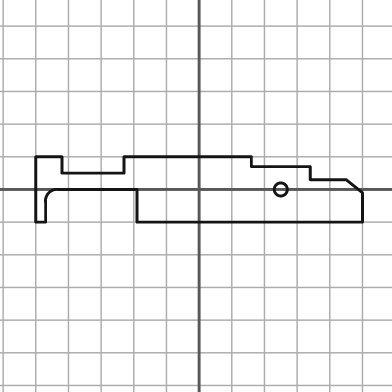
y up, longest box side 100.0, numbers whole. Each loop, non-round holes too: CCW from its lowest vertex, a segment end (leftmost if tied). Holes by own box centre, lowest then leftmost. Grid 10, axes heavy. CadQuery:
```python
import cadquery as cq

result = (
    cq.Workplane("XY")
    .moveTo(-50.0, -10.0)
    .lineTo(-47.0, -10.0)
    .lineTo(-47.0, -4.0)
    .threePointArc((-46.0, -1.0), (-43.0, 0.0))
    .lineTo(-19.0, 0.0)
    .lineTo(-19.0, -10.0)
    .lineTo(50.0, -10.0)
    .lineTo(50.0, -1.0)
    .lineTo(45.0, 3.0)
    .lineTo(34.0, 3.0)
    .lineTo(34.0, 7.0)
    .lineTo(16.0, 7.0)
    .lineTo(16.0, 10.0)
    .lineTo(-23.0, 10.0)
    .lineTo(-23.0, 5.0)
    .lineTo(-42.0, 5.0)
    .lineTo(-42.0, 10.0)
    .lineTo(-50.0, 10.0)
    .close()
    .moveTo(25.0, 0.0)
    .circle(2.0)
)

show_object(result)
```